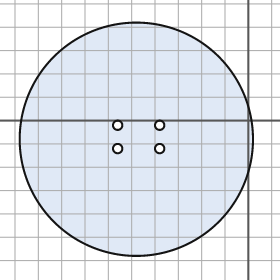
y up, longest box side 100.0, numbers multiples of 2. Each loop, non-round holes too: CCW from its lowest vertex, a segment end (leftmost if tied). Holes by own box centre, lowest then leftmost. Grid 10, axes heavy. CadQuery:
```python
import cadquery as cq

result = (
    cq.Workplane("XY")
    .moveTo(-48.0, -8.0)
    .circle(50.0)
    .moveTo(-56.0, -12.0)
    .circle(2.0)
    .moveTo(-38.0, -12.0)
    .circle(2.0)
    .moveTo(-56.0, -2.0)
    .circle(2.0)
    .moveTo(-38.0, -2.0)
    .circle(2.0)
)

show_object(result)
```